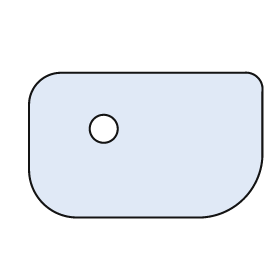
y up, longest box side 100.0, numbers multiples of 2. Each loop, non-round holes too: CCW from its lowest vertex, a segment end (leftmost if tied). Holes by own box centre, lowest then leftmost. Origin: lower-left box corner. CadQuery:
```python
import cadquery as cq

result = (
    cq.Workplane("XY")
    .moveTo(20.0, 0.0)
    .lineTo(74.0, 0.0)
    .threePointArc((92.0, 8.0), (100.0, 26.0))
    .lineTo(100.0, 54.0)
    .threePointArc((98.0, 60.0), (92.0, 62.0))
    .lineTo(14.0, 62.0)
    .threePointArc((4.0, 58.0), (0.0, 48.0))
    .lineTo(0.0, 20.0)
    .threePointArc((6.0, 6.0), (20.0, 0.0))
    .close()
    .moveTo(32.0, 38.0)
    .circle(6.0)
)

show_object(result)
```